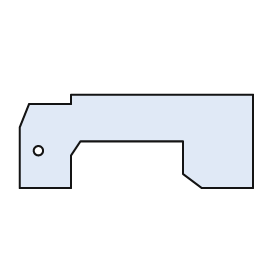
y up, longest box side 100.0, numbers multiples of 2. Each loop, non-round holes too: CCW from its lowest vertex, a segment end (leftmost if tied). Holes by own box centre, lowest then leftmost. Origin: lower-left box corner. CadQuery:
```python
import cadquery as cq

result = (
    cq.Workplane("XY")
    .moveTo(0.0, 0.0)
    .lineTo(22.0, 0.0)
    .lineTo(22.0, 14.0)
    .lineTo(26.0, 20.0)
    .lineTo(70.0, 20.0)
    .lineTo(70.0, 6.0)
    .lineTo(78.0, 0.0)
    .lineTo(100.0, 0.0)
    .lineTo(100.0, 40.0)
    .lineTo(22.0, 40.0)
    .lineTo(22.0, 36.0)
    .lineTo(4.0, 36.0)
    .lineTo(0.0, 26.0)
    .close()
    .moveTo(8.0, 16.0)
    .circle(2.0)
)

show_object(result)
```